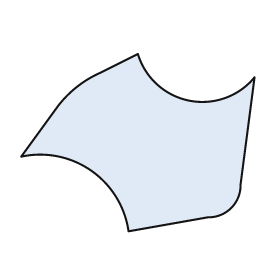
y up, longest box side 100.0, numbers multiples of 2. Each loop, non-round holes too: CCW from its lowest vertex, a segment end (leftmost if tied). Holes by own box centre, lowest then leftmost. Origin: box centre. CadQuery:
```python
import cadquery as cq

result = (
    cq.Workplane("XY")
    .moveTo(-4.0, -38.0)
    .lineTo(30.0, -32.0)
    .threePointArc((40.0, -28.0), (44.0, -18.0))
    .lineTo(50.0, 28.0)
    .threePointArc((22.0, 18.0), (0.0, 38.0))
    .lineTo(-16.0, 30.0)
    .threePointArc((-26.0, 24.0), (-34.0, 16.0))
    .lineTo(-50.0, -6.0)
    .threePointArc((-20.0, -12.0), (-4.0, -38.0))
    .close()
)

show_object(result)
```